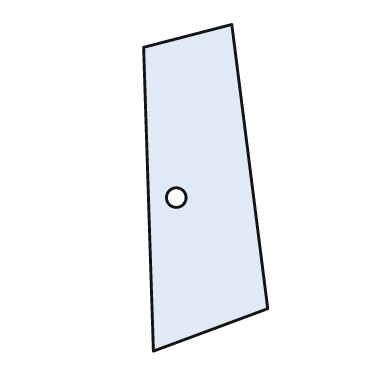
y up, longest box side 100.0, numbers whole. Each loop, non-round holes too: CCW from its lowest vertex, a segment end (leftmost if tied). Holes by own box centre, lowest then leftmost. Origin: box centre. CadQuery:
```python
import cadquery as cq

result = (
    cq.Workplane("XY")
    .moveTo(-16.0, -50.0)
    .lineTo(19.0, -37.0)
    .lineTo(8.0, 50.0)
    .lineTo(-19.0, 43.0)
    .close()
    .moveTo(-9.0, -3.0)
    .circle(3.0)
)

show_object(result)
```